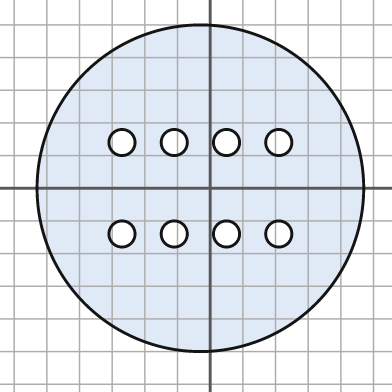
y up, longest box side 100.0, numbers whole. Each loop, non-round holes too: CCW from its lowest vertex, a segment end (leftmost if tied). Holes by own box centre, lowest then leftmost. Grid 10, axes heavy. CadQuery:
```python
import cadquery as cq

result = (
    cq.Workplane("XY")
    .moveTo(-3.0, 0.0)
    .circle(50.0)
    .moveTo(-27.0, -14.0)
    .circle(4.0)
    .moveTo(-11.0, -14.0)
    .circle(4.0)
    .moveTo(5.0, -14.0)
    .circle(4.0)
    .moveTo(21.0, -14.0)
    .circle(4.0)
    .moveTo(-27.0, 14.0)
    .circle(4.0)
    .moveTo(-11.0, 14.0)
    .circle(4.0)
    .moveTo(5.0, 14.0)
    .circle(4.0)
    .moveTo(21.0, 14.0)
    .circle(4.0)
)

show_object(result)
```